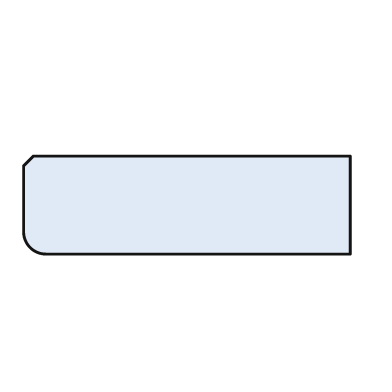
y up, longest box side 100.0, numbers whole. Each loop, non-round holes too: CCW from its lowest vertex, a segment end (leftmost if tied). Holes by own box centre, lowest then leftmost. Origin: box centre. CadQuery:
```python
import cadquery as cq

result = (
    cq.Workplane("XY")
    .moveTo(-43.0, -15.0)
    .lineTo(50.0, -15.0)
    .lineTo(50.0, 15.0)
    .lineTo(-47.0, 15.0)
    .lineTo(-50.0, 12.0)
    .lineTo(-50.0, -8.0)
    .threePointArc((-48.0, -13.0), (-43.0, -15.0))
    .close()
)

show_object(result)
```